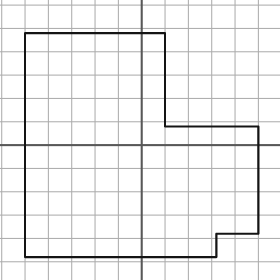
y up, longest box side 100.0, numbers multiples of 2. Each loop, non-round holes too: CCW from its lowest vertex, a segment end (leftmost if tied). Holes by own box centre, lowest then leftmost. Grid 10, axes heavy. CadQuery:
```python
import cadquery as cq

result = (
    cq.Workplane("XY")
    .moveTo(-50.0, -48.0)
    .lineTo(32.0, -48.0)
    .lineTo(32.0, -38.0)
    .lineTo(50.0, -38.0)
    .lineTo(50.0, 8.0)
    .lineTo(10.0, 8.0)
    .lineTo(10.0, 48.0)
    .lineTo(-50.0, 48.0)
    .close()
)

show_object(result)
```